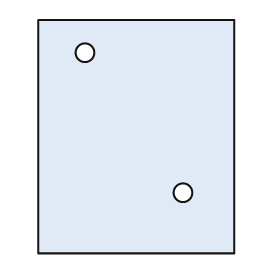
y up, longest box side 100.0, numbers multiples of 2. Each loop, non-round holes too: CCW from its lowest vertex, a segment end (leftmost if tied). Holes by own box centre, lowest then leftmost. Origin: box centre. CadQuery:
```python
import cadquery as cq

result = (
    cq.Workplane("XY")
    .moveTo(-42.0, -50.0)
    .lineTo(42.0, -50.0)
    .lineTo(42.0, 50.0)
    .lineTo(-42.0, 50.0)
    .close()
    .moveTo(20.0, -24.0)
    .circle(4.0)
    .moveTo(-22.0, 36.0)
    .circle(4.0)
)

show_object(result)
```